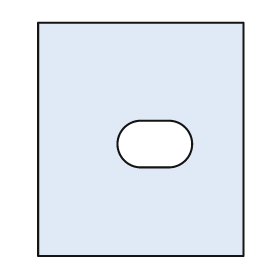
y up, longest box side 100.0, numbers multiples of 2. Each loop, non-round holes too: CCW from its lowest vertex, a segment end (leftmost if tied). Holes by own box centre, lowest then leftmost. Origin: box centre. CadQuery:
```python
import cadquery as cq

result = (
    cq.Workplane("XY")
    .moveTo(-44.0, -50.0)
    .lineTo(44.0, -50.0)
    .lineTo(44.0, 50.0)
    .lineTo(-44.0, 50.0)
    .close()
    .moveTo(0.0, -12.0)
    .lineTo(12.0, -12.0)
    .threePointArc((22.0, -2.0), (12.0, 8.0))
    .lineTo(0.0, 8.0)
    .threePointArc((-10.0, -2.0), (0.0, -12.0))
    .close()
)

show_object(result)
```